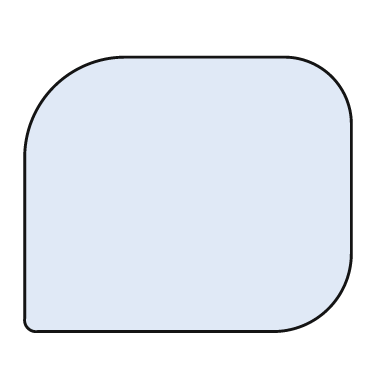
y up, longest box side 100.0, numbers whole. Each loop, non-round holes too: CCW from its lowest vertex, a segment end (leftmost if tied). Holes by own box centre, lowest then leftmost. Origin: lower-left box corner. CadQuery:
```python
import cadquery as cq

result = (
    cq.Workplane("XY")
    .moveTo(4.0, 0.0)
    .lineTo(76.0, 0.0)
    .threePointArc((93.0, 7.0), (100.0, 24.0))
    .lineTo(100.0, 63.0)
    .threePointArc((94.0, 78.0), (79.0, 84.0))
    .lineTo(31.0, 84.0)
    .threePointArc((9.0, 75.0), (0.0, 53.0))
    .lineTo(0.0, 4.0)
    .threePointArc((1.0, 1.0), (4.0, 0.0))
    .close()
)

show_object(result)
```